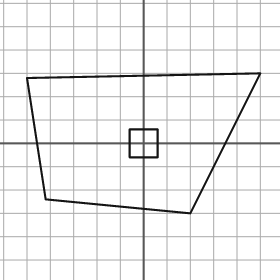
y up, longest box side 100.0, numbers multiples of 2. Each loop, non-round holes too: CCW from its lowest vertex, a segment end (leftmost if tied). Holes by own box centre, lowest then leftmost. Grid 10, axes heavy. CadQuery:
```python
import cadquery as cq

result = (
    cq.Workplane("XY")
    .moveTo(20.0, -30.0)
    .lineTo(50.0, 30.0)
    .lineTo(-50.0, 28.0)
    .lineTo(-42.0, -24.0)
    .close()
    .moveTo(-6.0, -6.0)
    .lineTo(6.0, -6.0)
    .lineTo(6.0, 6.0)
    .lineTo(-6.0, 6.0)
    .close()
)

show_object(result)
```